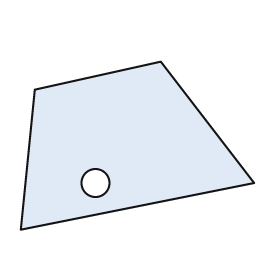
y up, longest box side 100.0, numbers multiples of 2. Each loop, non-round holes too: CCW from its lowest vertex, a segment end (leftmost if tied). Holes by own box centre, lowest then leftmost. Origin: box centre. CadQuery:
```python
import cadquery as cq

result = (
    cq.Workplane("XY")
    .moveTo(-50.0, -36.0)
    .lineTo(50.0, -16.0)
    .lineTo(10.0, 36.0)
    .lineTo(-44.0, 24.0)
    .close()
    .moveTo(-18.0, -16.0)
    .circle(6.0)
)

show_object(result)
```